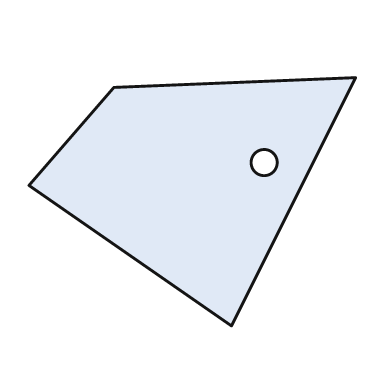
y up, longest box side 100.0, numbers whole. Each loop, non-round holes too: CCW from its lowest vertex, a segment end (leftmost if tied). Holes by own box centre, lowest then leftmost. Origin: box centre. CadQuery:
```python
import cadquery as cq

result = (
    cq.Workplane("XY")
    .moveTo(12.0, -38.0)
    .lineTo(50.0, 38.0)
    .lineTo(-24.0, 35.0)
    .lineTo(-50.0, 5.0)
    .close()
    .moveTo(22.0, 12.0)
    .circle(4.0)
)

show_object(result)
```